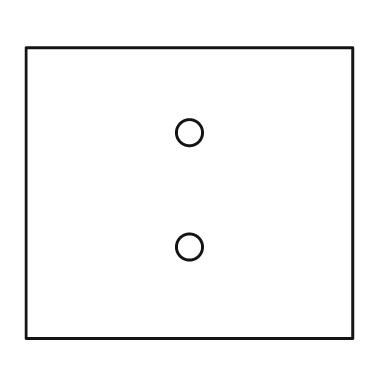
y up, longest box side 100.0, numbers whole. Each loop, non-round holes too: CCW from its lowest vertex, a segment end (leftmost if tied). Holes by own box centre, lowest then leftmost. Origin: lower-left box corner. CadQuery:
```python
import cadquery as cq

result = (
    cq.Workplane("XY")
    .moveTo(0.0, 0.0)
    .lineTo(100.0, 0.0)
    .lineTo(100.0, 89.0)
    .lineTo(0.0, 89.0)
    .close()
    .moveTo(50.0, 28.0)
    .circle(4.0)
    .moveTo(50.0, 63.0)
    .circle(4.0)
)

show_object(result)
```